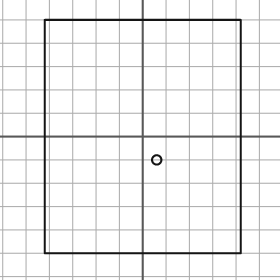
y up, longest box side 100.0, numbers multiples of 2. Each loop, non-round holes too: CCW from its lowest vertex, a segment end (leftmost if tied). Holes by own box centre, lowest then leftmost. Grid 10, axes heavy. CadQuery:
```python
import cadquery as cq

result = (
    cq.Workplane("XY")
    .moveTo(-42.0, -50.0)
    .lineTo(42.0, -50.0)
    .lineTo(42.0, 50.0)
    .lineTo(-42.0, 50.0)
    .close()
    .moveTo(6.0, -10.0)
    .circle(2.0)
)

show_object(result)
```